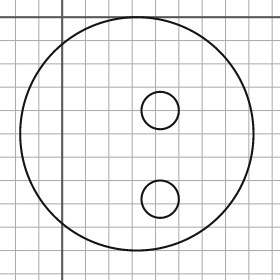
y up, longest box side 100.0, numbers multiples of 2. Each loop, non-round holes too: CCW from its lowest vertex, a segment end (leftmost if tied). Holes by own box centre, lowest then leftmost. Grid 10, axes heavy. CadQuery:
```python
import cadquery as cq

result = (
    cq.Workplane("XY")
    .moveTo(32.0, -50.0)
    .circle(50.0)
    .moveTo(42.0, -78.0)
    .circle(8.0)
    .moveTo(42.0, -40.0)
    .circle(8.0)
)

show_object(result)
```